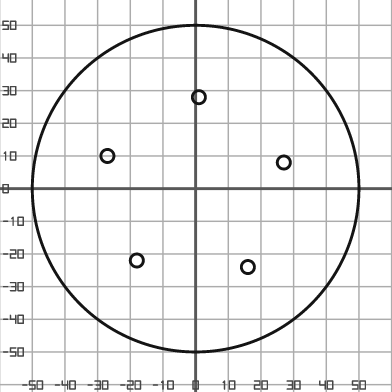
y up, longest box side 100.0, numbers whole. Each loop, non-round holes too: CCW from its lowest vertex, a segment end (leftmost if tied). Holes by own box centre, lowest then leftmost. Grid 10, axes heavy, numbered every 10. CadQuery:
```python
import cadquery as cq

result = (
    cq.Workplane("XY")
    .moveTo(0.0, 0.0)
    .circle(50.0)
    .moveTo(16.0, -24.0)
    .circle(2.0)
    .moveTo(-18.0, -22.0)
    .circle(2.0)
    .moveTo(27.0, 8.0)
    .circle(2.0)
    .moveTo(-27.0, 10.0)
    .circle(2.0)
    .moveTo(1.0, 28.0)
    .circle(2.0)
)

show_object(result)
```